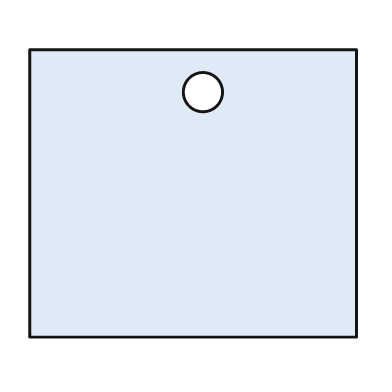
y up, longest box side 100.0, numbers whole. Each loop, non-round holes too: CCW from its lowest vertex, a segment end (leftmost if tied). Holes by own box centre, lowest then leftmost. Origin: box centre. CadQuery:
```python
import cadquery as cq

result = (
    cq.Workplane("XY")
    .moveTo(-50.0, -44.0)
    .lineTo(50.0, -44.0)
    .lineTo(50.0, 44.0)
    .lineTo(-50.0, 44.0)
    .close()
    .moveTo(3.0, 31.0)
    .circle(6.0)
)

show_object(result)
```